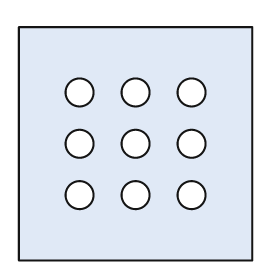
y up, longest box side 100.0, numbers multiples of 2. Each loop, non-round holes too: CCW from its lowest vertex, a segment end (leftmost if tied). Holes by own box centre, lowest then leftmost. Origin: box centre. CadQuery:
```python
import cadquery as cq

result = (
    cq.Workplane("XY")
    .moveTo(-50.0, -50.0)
    .lineTo(50.0, -50.0)
    .lineTo(50.0, 50.0)
    .lineTo(-50.0, 50.0)
    .close()
    .moveTo(-24.0, -22.0)
    .circle(6.0)
    .moveTo(0.0, -22.0)
    .circle(6.0)
    .moveTo(24.0, -22.0)
    .circle(6.0)
    .moveTo(-24.0, 0.0)
    .circle(6.0)
    .moveTo(0.0, 0.0)
    .circle(6.0)
    .moveTo(24.0, 0.0)
    .circle(6.0)
    .moveTo(-24.0, 22.0)
    .circle(6.0)
    .moveTo(0.0, 22.0)
    .circle(6.0)
    .moveTo(24.0, 22.0)
    .circle(6.0)
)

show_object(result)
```